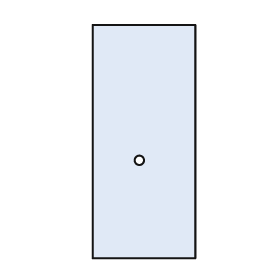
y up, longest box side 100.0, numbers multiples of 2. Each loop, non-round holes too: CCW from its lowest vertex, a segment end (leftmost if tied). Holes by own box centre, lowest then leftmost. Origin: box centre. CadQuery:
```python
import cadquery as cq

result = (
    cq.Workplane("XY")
    .moveTo(-22.0, -50.0)
    .lineTo(22.0, -50.0)
    .lineTo(22.0, 50.0)
    .lineTo(-22.0, 50.0)
    .close()
    .moveTo(-2.0, -8.0)
    .circle(2.0)
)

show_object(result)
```